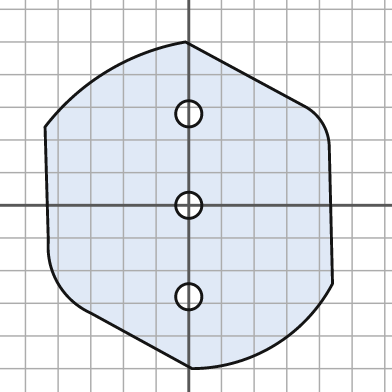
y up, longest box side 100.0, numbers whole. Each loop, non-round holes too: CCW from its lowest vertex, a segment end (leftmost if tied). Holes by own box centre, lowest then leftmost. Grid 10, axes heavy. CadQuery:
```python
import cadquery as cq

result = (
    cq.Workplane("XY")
    .moveTo(1.0, -50.0)
    .threePointArc((26.0, -43.0), (44.0, -24.0))
    .lineTo(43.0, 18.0)
    .threePointArc((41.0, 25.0), (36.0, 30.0))
    .lineTo(-1.0, 50.0)
    .threePointArc((-25.0, 41.0), (-44.0, 24.0))
    .lineTo(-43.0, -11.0)
    .threePointArc((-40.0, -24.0), (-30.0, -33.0))
    .close()
    .moveTo(0.0, -28.0)
    .circle(4.0)
    .moveTo(0.0, 0.0)
    .circle(4.0)
    .moveTo(0.0, 28.0)
    .circle(4.0)
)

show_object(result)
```